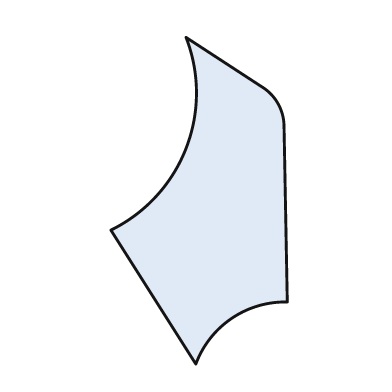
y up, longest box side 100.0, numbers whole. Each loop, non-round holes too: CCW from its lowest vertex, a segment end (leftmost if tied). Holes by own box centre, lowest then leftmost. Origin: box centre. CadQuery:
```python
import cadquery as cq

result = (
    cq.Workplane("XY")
    .moveTo(-1.0, -50.0)
    .threePointArc((10.0, -36.0), (27.0, -31.0))
    .lineTo(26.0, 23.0)
    .threePointArc((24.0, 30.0), (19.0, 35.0))
    .lineTo(-4.0, 50.0)
    .threePointArc((-4.0, 16.0), (-27.0, -9.0))
    .close()
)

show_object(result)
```